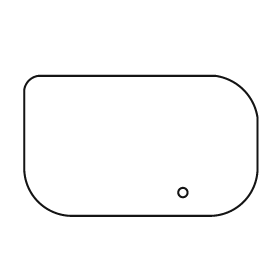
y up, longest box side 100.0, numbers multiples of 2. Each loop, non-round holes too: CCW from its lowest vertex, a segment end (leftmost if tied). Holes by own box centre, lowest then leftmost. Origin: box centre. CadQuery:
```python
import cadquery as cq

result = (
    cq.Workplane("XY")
    .moveTo(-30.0, -30.0)
    .lineTo(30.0, -30.0)
    .threePointArc((44.0, -24.0), (50.0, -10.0))
    .lineTo(50.0, 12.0)
    .threePointArc((44.0, 24.0), (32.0, 30.0))
    .lineTo(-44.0, 30.0)
    .threePointArc((-48.0, 28.0), (-50.0, 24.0))
    .lineTo(-50.0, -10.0)
    .threePointArc((-44.0, -24.0), (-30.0, -30.0))
    .close()
    .moveTo(18.0, -20.0)
    .circle(2.0)
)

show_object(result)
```